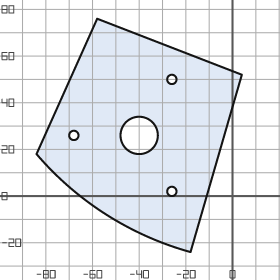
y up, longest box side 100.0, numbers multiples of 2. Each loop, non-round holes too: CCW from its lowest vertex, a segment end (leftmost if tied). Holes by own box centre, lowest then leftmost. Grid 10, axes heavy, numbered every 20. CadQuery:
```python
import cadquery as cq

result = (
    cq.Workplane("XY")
    .moveTo(-18.0, -24.0)
    .lineTo(4.0, 52.0)
    .lineTo(-58.0, 76.0)
    .lineTo(-84.0, 18.0)
    .threePointArc((-54.0, -8.0), (-18.0, -24.0))
    .close()
    .moveTo(-26.0, 2.0)
    .circle(2.0)
    .moveTo(-68.0, 26.0)
    .circle(2.0)
    .moveTo(-40.0, 26.0)
    .circle(8.0)
    .moveTo(-26.0, 50.0)
    .circle(2.0)
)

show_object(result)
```